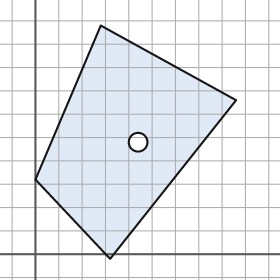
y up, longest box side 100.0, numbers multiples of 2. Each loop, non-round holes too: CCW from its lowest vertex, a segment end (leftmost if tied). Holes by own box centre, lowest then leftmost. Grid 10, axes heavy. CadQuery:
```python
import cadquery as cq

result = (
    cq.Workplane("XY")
    .moveTo(32.0, -2.0)
    .lineTo(86.0, 66.0)
    .lineTo(28.0, 98.0)
    .lineTo(0.0, 32.0)
    .close()
    .moveTo(44.0, 48.0)
    .circle(4.0)
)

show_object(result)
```